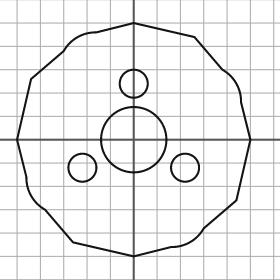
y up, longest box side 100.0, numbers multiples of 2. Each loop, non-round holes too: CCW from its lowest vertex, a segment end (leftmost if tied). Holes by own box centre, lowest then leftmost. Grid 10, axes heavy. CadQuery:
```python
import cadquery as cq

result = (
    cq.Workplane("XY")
    .moveTo(0.0, -50.0)
    .lineTo(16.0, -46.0)
    .threePointArc((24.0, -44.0), (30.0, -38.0))
    .lineTo(44.0, -26.0)
    .lineTo(50.0, 0.0)
    .lineTo(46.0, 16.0)
    .threePointArc((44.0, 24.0), (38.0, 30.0))
    .lineTo(26.0, 44.0)
    .lineTo(0.0, 50.0)
    .lineTo(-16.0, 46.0)
    .threePointArc((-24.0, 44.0), (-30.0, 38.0))
    .lineTo(-44.0, 26.0)
    .lineTo(-50.0, 0.0)
    .lineTo(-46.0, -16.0)
    .threePointArc((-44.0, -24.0), (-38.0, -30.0))
    .lineTo(-26.0, -44.0)
    .close()
    .moveTo(-22.0, -12.0)
    .circle(6.0)
    .moveTo(22.0, -12.0)
    .circle(6.0)
    .moveTo(0.0, 0.0)
    .circle(14.0)
    .moveTo(0.0, 24.0)
    .circle(6.0)
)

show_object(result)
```